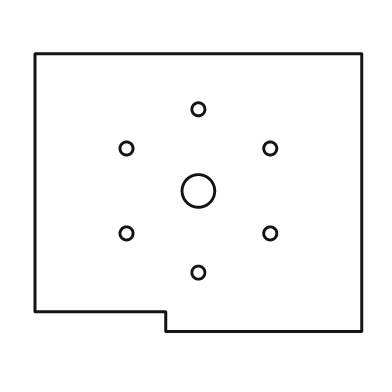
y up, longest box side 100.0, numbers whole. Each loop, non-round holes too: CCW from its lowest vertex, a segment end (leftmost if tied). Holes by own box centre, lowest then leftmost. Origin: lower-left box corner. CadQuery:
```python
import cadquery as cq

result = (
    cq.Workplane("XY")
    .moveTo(40.0, 0.0)
    .lineTo(100.0, 0.0)
    .lineTo(100.0, 85.0)
    .lineTo(0.0, 85.0)
    .lineTo(0.0, 6.0)
    .lineTo(40.0, 6.0)
    .close()
    .moveTo(50.0, 18.0)
    .circle(2.0)
    .moveTo(28.0, 30.0)
    .circle(2.0)
    .moveTo(72.0, 30.0)
    .circle(2.0)
    .moveTo(50.0, 43.0)
    .circle(5.0)
    .moveTo(28.0, 56.0)
    .circle(2.0)
    .moveTo(72.0, 56.0)
    .circle(2.0)
    .moveTo(50.0, 68.0)
    .circle(2.0)
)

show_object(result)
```